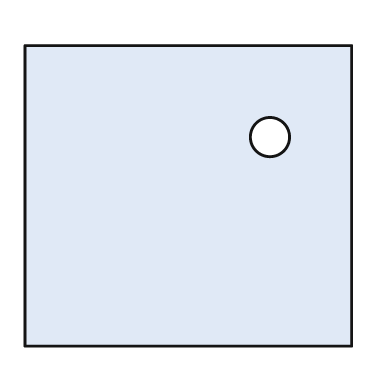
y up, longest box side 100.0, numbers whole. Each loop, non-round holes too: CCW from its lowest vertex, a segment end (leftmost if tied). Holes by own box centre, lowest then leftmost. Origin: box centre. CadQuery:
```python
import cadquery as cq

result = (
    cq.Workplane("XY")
    .moveTo(-50.0, -46.0)
    .lineTo(50.0, -46.0)
    .lineTo(50.0, 46.0)
    .lineTo(-50.0, 46.0)
    .close()
    .moveTo(25.0, 18.0)
    .circle(6.0)
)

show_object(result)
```